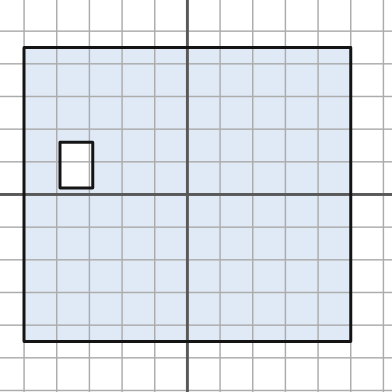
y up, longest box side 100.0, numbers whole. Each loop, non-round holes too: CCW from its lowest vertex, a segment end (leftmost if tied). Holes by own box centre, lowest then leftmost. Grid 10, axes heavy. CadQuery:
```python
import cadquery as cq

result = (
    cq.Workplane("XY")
    .moveTo(-50.0, -45.0)
    .lineTo(50.0, -45.0)
    .lineTo(50.0, 45.0)
    .lineTo(-50.0, 45.0)
    .close()
    .moveTo(-39.0, 2.0)
    .lineTo(-29.0, 2.0)
    .lineTo(-29.0, 16.0)
    .lineTo(-39.0, 16.0)
    .close()
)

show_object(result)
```